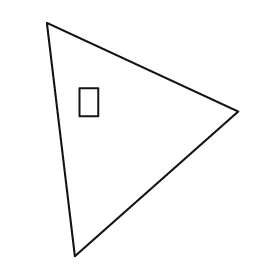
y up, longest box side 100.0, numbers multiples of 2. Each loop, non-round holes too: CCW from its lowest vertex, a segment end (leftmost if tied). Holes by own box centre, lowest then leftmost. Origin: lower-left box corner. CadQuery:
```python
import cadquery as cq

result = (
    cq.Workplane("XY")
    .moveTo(12.0, 0.0)
    .lineTo(82.0, 62.0)
    .lineTo(0.0, 100.0)
    .close()
    .moveTo(14.0, 60.0)
    .lineTo(22.0, 60.0)
    .lineTo(22.0, 72.0)
    .lineTo(14.0, 72.0)
    .close()
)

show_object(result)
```